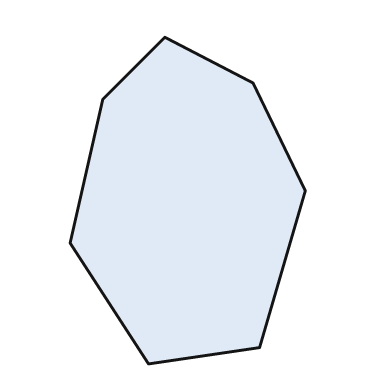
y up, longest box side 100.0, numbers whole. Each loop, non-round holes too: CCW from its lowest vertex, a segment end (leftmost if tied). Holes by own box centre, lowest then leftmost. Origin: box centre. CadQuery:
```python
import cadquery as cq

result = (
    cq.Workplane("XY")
    .moveTo(-12.0, -50.0)
    .lineTo(22.0, -45.0)
    .lineTo(36.0, 3.0)
    .lineTo(20.0, 36.0)
    .lineTo(-7.0, 50.0)
    .lineTo(-26.0, 31.0)
    .lineTo(-36.0, -13.0)
    .close()
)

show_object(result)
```